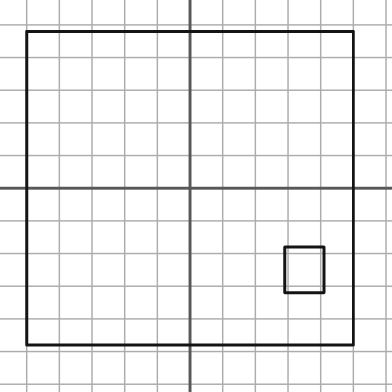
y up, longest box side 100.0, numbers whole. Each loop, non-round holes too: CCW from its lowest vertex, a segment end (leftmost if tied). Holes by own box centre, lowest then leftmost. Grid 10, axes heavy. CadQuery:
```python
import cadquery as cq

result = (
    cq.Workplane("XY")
    .moveTo(-50.0, -48.0)
    .lineTo(50.0, -48.0)
    .lineTo(50.0, 48.0)
    .lineTo(-50.0, 48.0)
    .close()
    .moveTo(29.0, -32.0)
    .lineTo(41.0, -32.0)
    .lineTo(41.0, -18.0)
    .lineTo(29.0, -18.0)
    .close()
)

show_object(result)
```